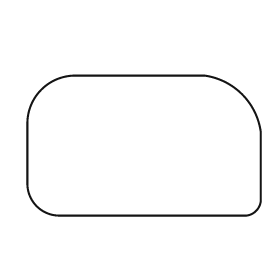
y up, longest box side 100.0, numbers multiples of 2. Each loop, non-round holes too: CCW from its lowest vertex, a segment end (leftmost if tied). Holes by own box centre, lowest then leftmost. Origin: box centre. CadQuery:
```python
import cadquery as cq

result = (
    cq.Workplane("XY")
    .moveTo(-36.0, -30.0)
    .lineTo(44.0, -30.0)
    .threePointArc((48.0, -28.0), (50.0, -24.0))
    .lineTo(50.0, 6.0)
    .threePointArc((42.0, 22.0), (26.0, 30.0))
    .lineTo(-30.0, 30.0)
    .threePointArc((-44.0, 24.0), (-50.0, 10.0))
    .lineTo(-50.0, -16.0)
    .threePointArc((-46.0, -26.0), (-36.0, -30.0))
    .close()
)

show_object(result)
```